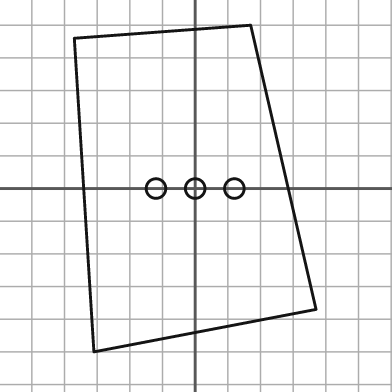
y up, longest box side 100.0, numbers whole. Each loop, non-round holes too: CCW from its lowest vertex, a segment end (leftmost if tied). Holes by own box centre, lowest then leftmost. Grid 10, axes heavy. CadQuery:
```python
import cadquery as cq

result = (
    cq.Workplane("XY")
    .moveTo(-31.0, -50.0)
    .lineTo(37.0, -37.0)
    .lineTo(17.0, 50.0)
    .lineTo(-37.0, 46.0)
    .close()
    .moveTo(-12.0, 0.0)
    .circle(3.0)
    .moveTo(0.0, 0.0)
    .circle(3.0)
    .moveTo(12.0, 0.0)
    .circle(3.0)
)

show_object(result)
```